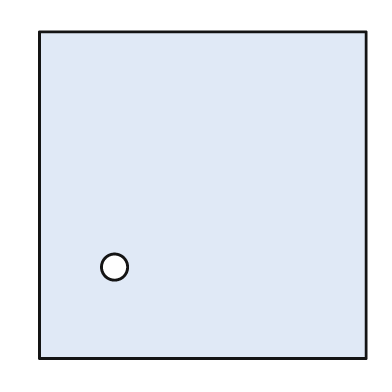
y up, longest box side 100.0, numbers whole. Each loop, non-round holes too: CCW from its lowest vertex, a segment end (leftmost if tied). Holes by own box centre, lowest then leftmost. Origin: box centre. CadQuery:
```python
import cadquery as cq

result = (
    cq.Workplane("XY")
    .moveTo(-50.0, -50.0)
    .lineTo(50.0, -50.0)
    .lineTo(50.0, 50.0)
    .lineTo(-50.0, 50.0)
    .close()
    .moveTo(-27.0, -22.0)
    .circle(4.0)
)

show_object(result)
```